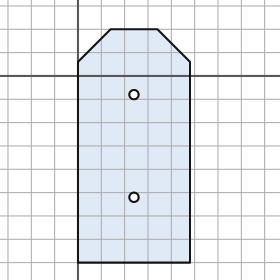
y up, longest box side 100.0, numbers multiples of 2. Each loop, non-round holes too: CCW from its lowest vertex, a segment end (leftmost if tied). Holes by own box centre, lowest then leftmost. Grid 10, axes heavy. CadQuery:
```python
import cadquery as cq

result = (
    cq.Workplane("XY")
    .moveTo(0.0, -80.0)
    .lineTo(48.0, -80.0)
    .lineTo(48.0, 6.0)
    .lineTo(34.0, 20.0)
    .lineTo(14.0, 20.0)
    .lineTo(0.0, 6.0)
    .close()
    .moveTo(24.0, -52.0)
    .circle(2.0)
    .moveTo(24.0, -8.0)
    .circle(2.0)
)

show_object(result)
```